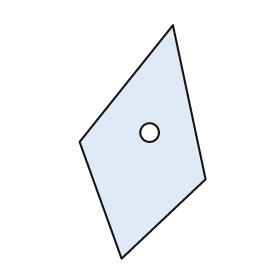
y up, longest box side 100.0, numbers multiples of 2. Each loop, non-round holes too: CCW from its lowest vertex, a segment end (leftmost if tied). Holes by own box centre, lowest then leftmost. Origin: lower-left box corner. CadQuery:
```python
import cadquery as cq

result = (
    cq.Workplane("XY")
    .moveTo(18.0, 0.0)
    .lineTo(54.0, 34.0)
    .lineTo(40.0, 100.0)
    .lineTo(0.0, 50.0)
    .close()
    .moveTo(30.0, 54.0)
    .circle(4.0)
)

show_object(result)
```